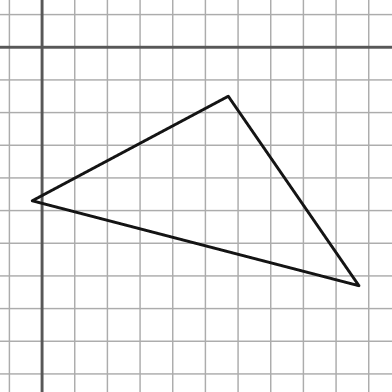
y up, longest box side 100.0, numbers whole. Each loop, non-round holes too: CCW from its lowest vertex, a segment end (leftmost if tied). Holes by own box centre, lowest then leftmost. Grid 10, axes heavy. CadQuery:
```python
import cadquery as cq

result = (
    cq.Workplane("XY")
    .moveTo(97.0, -73.0)
    .lineTo(57.0, -15.0)
    .lineTo(-3.0, -47.0)
    .close()
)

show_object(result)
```